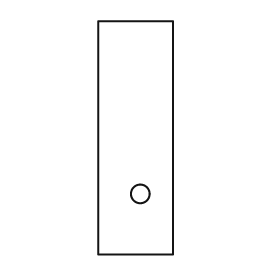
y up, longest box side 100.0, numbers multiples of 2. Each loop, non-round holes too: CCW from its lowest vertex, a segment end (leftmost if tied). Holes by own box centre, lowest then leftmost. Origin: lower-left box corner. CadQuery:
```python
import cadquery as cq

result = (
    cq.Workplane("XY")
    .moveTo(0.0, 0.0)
    .lineTo(32.0, 0.0)
    .lineTo(32.0, 100.0)
    .lineTo(0.0, 100.0)
    .close()
    .moveTo(18.0, 26.0)
    .circle(4.0)
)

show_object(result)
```